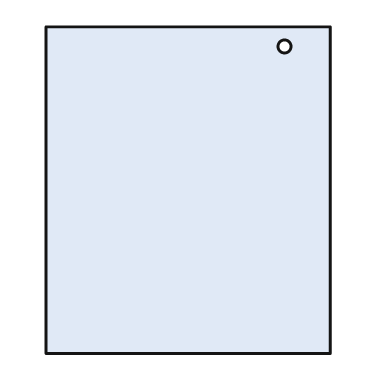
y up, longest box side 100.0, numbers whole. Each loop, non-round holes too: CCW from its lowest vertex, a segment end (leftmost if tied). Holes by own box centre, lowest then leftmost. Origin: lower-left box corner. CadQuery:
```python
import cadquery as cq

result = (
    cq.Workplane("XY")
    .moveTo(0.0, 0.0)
    .lineTo(87.0, 0.0)
    .lineTo(87.0, 100.0)
    .lineTo(0.0, 100.0)
    .close()
    .moveTo(73.0, 94.0)
    .circle(2.0)
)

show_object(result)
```